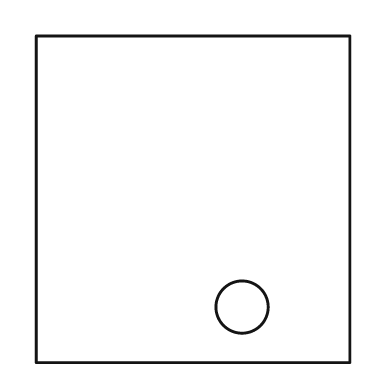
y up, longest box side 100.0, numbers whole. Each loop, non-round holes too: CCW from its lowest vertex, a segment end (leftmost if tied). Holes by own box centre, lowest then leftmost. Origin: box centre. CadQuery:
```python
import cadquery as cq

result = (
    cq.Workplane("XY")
    .moveTo(-48.0, -50.0)
    .lineTo(48.0, -50.0)
    .lineTo(48.0, 50.0)
    .lineTo(-48.0, 50.0)
    .close()
    .moveTo(15.0, -33.0)
    .circle(8.0)
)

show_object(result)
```